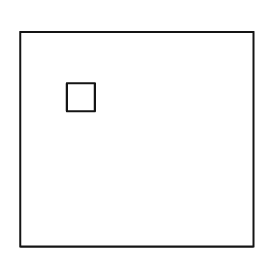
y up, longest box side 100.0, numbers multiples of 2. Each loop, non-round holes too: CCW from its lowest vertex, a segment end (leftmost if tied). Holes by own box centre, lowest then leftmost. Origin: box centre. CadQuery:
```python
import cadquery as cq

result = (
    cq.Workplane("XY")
    .moveTo(-50.0, -46.0)
    .lineTo(50.0, -46.0)
    .lineTo(50.0, 46.0)
    .lineTo(-50.0, 46.0)
    .close()
    .moveTo(-30.0, 12.0)
    .lineTo(-18.0, 12.0)
    .lineTo(-18.0, 24.0)
    .lineTo(-30.0, 24.0)
    .close()
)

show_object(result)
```